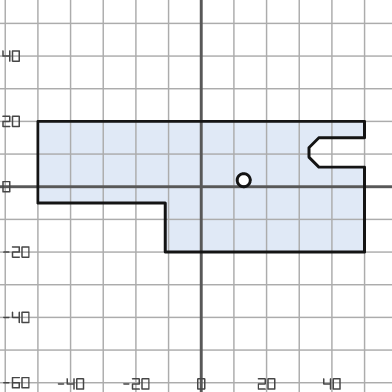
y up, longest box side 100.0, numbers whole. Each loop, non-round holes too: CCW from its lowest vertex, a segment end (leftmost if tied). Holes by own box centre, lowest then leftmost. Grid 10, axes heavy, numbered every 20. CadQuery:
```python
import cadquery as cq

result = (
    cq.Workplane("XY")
    .moveTo(-11.0, -20.0)
    .lineTo(50.0, -20.0)
    .lineTo(50.0, 6.0)
    .lineTo(36.0, 6.0)
    .lineTo(33.0, 9.0)
    .lineTo(33.0, 12.0)
    .lineTo(36.0, 15.0)
    .lineTo(50.0, 15.0)
    .lineTo(50.0, 20.0)
    .lineTo(-50.0, 20.0)
    .lineTo(-50.0, -5.0)
    .lineTo(-11.0, -5.0)
    .close()
    .moveTo(13.0, 2.0)
    .circle(2.0)
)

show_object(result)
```